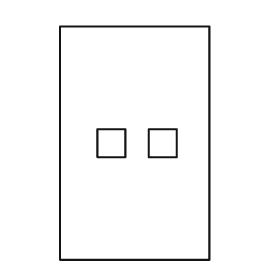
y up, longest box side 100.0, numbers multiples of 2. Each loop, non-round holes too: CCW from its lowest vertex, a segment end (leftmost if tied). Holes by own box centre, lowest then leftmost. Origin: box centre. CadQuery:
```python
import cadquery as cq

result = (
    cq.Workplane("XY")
    .moveTo(-32.0, -50.0)
    .lineTo(32.0, -50.0)
    .lineTo(32.0, 50.0)
    .lineTo(-32.0, 50.0)
    .close()
    .moveTo(-16.0, -6.0)
    .lineTo(-4.0, -6.0)
    .lineTo(-4.0, 6.0)
    .lineTo(-16.0, 6.0)
    .close()
    .moveTo(6.0, -6.0)
    .lineTo(18.0, -6.0)
    .lineTo(18.0, 6.0)
    .lineTo(6.0, 6.0)
    .close()
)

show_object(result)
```